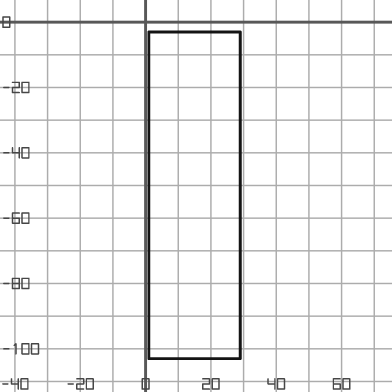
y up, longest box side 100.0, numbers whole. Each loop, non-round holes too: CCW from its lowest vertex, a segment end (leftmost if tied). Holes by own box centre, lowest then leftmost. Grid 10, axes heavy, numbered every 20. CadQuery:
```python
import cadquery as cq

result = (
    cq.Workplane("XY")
    .moveTo(1.0, -103.0)
    .lineTo(29.0, -103.0)
    .lineTo(29.0, -3.0)
    .lineTo(1.0, -3.0)
    .close()
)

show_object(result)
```